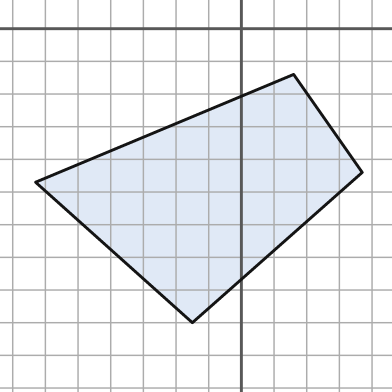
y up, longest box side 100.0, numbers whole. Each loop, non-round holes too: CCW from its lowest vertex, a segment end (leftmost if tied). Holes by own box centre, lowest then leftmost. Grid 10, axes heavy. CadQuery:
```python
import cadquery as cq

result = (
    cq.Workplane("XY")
    .moveTo(-15.0, -90.0)
    .lineTo(37.0, -44.0)
    .lineTo(16.0, -14.0)
    .lineTo(-63.0, -47.0)
    .close()
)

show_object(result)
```